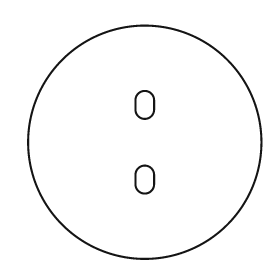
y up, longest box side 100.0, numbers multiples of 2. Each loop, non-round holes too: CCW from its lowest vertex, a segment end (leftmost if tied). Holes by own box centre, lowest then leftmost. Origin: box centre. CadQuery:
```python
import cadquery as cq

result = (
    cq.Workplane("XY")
    .moveTo(0.0, 0.0)
    .circle(50.0)
    .moveTo(-4.0, -18.0)
    .threePointArc((0.0, -22.0), (4.0, -18.0))
    .lineTo(4.0, -14.0)
    .threePointArc((0.0, -10.0), (-4.0, -14.0))
    .close()
    .moveTo(-4.0, 14.0)
    .threePointArc((0.0, 10.0), (4.0, 14.0))
    .lineTo(4.0, 18.0)
    .threePointArc((0.0, 22.0), (-4.0, 18.0))
    .close()
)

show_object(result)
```